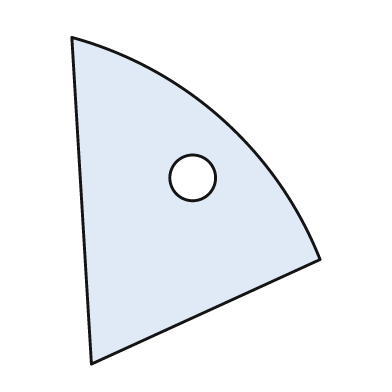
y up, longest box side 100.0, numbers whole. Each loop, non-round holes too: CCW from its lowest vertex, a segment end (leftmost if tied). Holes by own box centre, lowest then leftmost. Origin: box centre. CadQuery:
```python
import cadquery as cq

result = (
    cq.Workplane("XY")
    .moveTo(-32.0, -50.0)
    .lineTo(38.0, -18.0)
    .threePointArc((8.0, 25.0), (-38.0, 50.0))
    .close()
    .moveTo(-1.0, 7.0)
    .circle(7.0)
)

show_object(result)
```